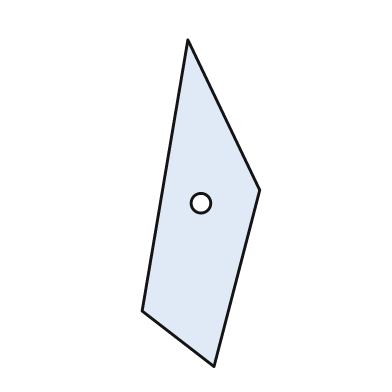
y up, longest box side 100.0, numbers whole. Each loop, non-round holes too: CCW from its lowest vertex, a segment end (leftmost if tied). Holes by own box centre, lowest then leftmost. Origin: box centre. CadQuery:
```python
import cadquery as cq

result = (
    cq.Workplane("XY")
    .moveTo(4.0, -50.0)
    .lineTo(18.0, 4.0)
    .lineTo(-4.0, 50.0)
    .lineTo(-18.0, -33.0)
    .close()
    .moveTo(0.0, 0.0)
    .circle(3.0)
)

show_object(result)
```